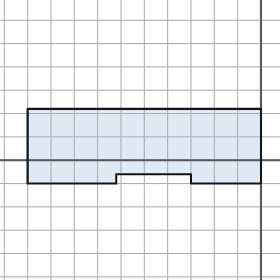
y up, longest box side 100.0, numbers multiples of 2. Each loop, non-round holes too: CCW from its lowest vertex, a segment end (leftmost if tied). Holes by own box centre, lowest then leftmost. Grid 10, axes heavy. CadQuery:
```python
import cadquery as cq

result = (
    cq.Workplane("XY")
    .moveTo(-100.0, -10.0)
    .lineTo(-62.0, -10.0)
    .lineTo(-62.0, -6.0)
    .lineTo(-30.0, -6.0)
    .lineTo(-30.0, -10.0)
    .lineTo(0.0, -10.0)
    .lineTo(0.0, 22.0)
    .lineTo(-100.0, 22.0)
    .close()
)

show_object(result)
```